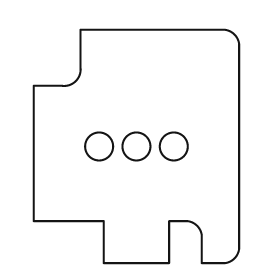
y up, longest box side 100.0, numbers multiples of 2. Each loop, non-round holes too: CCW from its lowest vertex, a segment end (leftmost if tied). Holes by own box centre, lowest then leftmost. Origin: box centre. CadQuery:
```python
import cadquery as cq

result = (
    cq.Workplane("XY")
    .moveTo(-14.0, -50.0)
    .lineTo(14.0, -50.0)
    .lineTo(14.0, -32.0)
    .lineTo(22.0, -32.0)
    .threePointArc((26.0, -34.0), (28.0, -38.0))
    .lineTo(28.0, -50.0)
    .lineTo(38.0, -50.0)
    .threePointArc((42.0, -48.0), (44.0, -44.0))
    .lineTo(44.0, 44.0)
    .threePointArc((42.0, 48.0), (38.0, 50.0))
    .lineTo(-24.0, 50.0)
    .lineTo(-24.0, 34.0)
    .threePointArc((-26.0, 28.0), (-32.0, 26.0))
    .lineTo(-44.0, 26.0)
    .lineTo(-44.0, -32.0)
    .lineTo(-14.0, -32.0)
    .close()
    .moveTo(-16.0, 0.0)
    .circle(6.0)
    .moveTo(0.0, 0.0)
    .circle(6.0)
    .moveTo(16.0, 0.0)
    .circle(6.0)
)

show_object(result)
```